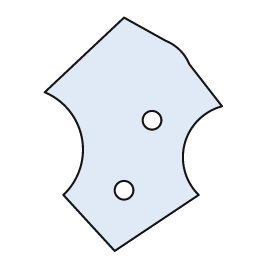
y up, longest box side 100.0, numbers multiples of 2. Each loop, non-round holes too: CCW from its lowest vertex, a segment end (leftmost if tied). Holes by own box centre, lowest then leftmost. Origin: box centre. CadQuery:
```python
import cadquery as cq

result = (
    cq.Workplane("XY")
    .moveTo(-8.0, -50.0)
    .lineTo(28.0, -26.0)
    .threePointArc((22.0, -4.0), (38.0, 12.0))
    .lineTo(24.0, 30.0)
    .threePointArc((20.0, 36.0), (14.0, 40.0))
    .lineTo(-4.0, 50.0)
    .lineTo(-38.0, 18.0)
    .threePointArc((-22.0, -2.0), (-30.0, -26.0))
    .close()
    .moveTo(-4.0, -24.0)
    .circle(4.0)
    .moveTo(8.0, 6.0)
    .circle(4.0)
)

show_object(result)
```